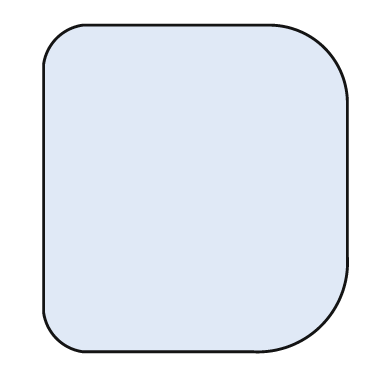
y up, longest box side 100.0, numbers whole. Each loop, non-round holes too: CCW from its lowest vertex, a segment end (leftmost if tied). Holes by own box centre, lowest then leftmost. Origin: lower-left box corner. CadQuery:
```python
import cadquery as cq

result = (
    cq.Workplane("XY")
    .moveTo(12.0, 0.0)
    .lineTo(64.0, 0.0)
    .threePointArc((85.0, 8.0), (93.0, 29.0))
    .lineTo(93.0, 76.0)
    .threePointArc((86.0, 93.0), (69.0, 100.0))
    .lineTo(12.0, 100.0)
    .threePointArc((4.0, 96.0), (0.0, 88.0))
    .lineTo(0.0, 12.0)
    .threePointArc((4.0, 4.0), (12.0, 0.0))
    .close()
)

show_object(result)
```